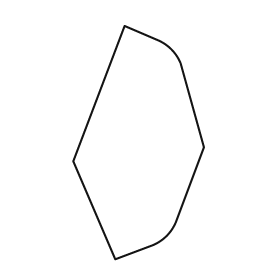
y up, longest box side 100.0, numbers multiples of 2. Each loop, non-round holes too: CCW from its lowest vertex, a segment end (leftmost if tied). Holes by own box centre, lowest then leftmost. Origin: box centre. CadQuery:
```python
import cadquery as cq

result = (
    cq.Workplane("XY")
    .moveTo(-10.0, -50.0)
    .lineTo(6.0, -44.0)
    .threePointArc((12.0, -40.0), (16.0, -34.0))
    .lineTo(28.0, -2.0)
    .lineTo(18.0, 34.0)
    .threePointArc((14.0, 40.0), (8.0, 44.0))
    .lineTo(-6.0, 50.0)
    .lineTo(-28.0, -8.0)
    .close()
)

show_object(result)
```